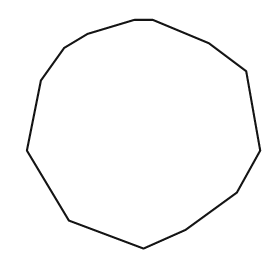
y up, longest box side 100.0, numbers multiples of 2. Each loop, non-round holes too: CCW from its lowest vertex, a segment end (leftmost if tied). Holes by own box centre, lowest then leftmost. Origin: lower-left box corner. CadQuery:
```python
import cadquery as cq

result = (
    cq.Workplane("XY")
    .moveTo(50.0, 0.0)
    .lineTo(68.0, 8.0)
    .lineTo(90.0, 24.0)
    .lineTo(100.0, 42.0)
    .lineTo(94.0, 76.0)
    .lineTo(78.0, 88.0)
    .lineTo(54.0, 98.0)
    .lineTo(46.0, 98.0)
    .lineTo(26.0, 92.0)
    .lineTo(16.0, 86.0)
    .lineTo(6.0, 72.0)
    .lineTo(0.0, 42.0)
    .lineTo(18.0, 12.0)
    .close()
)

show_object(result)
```